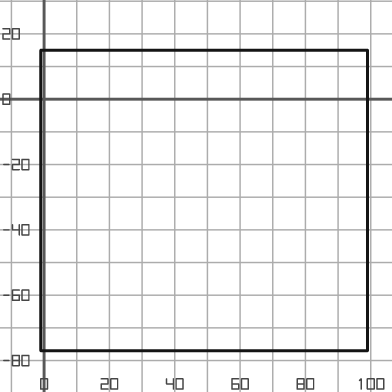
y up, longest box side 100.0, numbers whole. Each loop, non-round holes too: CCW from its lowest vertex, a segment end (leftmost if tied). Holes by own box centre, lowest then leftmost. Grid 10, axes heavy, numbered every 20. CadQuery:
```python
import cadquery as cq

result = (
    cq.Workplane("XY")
    .moveTo(-1.0, -77.0)
    .lineTo(99.0, -77.0)
    .lineTo(99.0, 15.0)
    .lineTo(-1.0, 15.0)
    .close()
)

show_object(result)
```